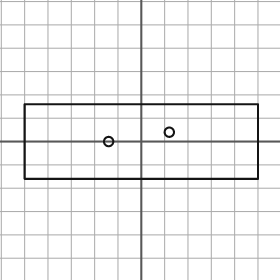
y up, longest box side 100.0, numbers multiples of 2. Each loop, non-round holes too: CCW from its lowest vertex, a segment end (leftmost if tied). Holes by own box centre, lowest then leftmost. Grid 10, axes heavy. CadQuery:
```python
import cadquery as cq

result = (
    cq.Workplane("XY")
    .moveTo(-50.0, -16.0)
    .lineTo(50.0, -16.0)
    .lineTo(50.0, 16.0)
    .lineTo(-50.0, 16.0)
    .close()
    .moveTo(-14.0, 0.0)
    .circle(2.0)
    .moveTo(12.0, 4.0)
    .circle(2.0)
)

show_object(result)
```